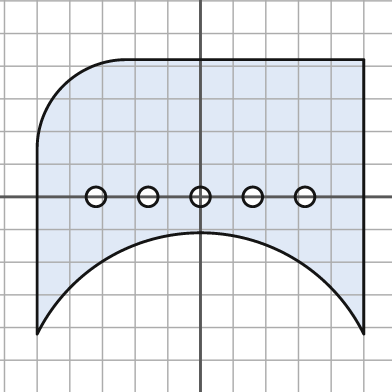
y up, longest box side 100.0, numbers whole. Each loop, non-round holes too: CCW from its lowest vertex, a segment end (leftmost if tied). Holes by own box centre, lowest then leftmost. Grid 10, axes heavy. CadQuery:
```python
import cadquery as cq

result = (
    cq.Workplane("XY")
    .moveTo(-50.0, -42.0)
    .threePointArc((0.0, -11.0), (50.0, -42.0))
    .lineTo(50.0, 42.0)
    .lineTo(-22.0, 42.0)
    .threePointArc((-42.0, 34.0), (-50.0, 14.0))
    .close()
    .moveTo(-32.0, 0.0)
    .circle(3.0)
    .moveTo(-16.0, 0.0)
    .circle(3.0)
    .moveTo(0.0, 0.0)
    .circle(3.0)
    .moveTo(16.0, 0.0)
    .circle(3.0)
    .moveTo(32.0, 0.0)
    .circle(3.0)
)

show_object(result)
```